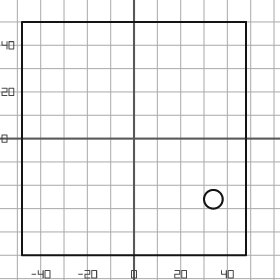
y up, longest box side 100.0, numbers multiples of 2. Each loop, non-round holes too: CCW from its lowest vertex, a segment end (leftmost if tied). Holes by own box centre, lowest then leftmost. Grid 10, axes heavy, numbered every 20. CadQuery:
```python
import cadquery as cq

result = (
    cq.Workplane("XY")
    .moveTo(-48.0, -50.0)
    .lineTo(48.0, -50.0)
    .lineTo(48.0, 50.0)
    .lineTo(-48.0, 50.0)
    .close()
    .moveTo(34.0, -26.0)
    .circle(4.0)
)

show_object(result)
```